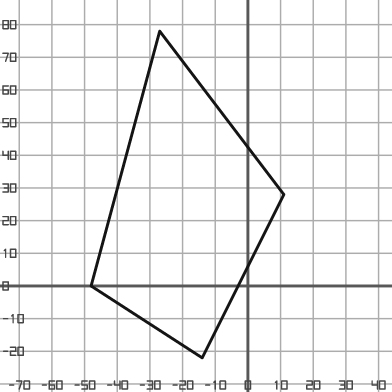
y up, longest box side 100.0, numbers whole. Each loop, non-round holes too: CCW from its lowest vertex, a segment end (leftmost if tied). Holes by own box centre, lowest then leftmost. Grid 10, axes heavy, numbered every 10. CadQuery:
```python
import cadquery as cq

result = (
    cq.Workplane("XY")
    .moveTo(-14.0, -22.0)
    .lineTo(11.0, 28.0)
    .lineTo(-27.0, 78.0)
    .lineTo(-48.0, 0.0)
    .close()
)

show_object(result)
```